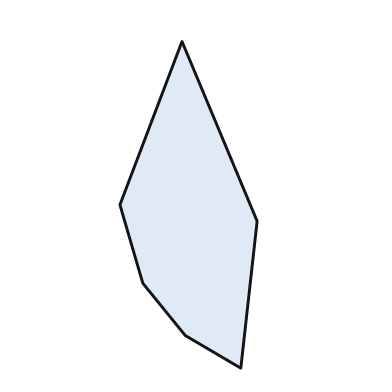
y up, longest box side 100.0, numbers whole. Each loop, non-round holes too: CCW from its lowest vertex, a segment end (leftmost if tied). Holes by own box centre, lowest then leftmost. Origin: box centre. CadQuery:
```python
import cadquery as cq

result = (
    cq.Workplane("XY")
    .moveTo(16.0, -50.0)
    .lineTo(21.0, -5.0)
    .lineTo(-2.0, 50.0)
    .lineTo(-21.0, 0.0)
    .lineTo(-14.0, -24.0)
    .lineTo(-1.0, -40.0)
    .close()
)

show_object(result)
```